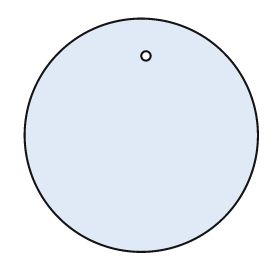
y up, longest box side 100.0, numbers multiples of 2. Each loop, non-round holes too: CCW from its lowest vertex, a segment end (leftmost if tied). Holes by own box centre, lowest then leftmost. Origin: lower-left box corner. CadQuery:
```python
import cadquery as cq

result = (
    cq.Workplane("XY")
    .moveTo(50.0, 50.0)
    .circle(50.0)
    .moveTo(52.0, 84.0)
    .circle(2.0)
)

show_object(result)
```